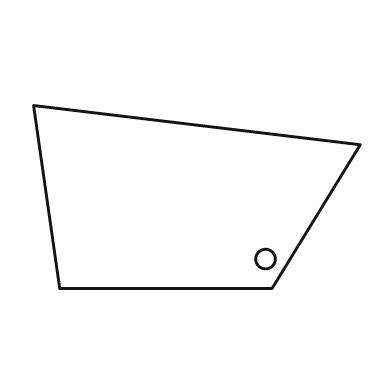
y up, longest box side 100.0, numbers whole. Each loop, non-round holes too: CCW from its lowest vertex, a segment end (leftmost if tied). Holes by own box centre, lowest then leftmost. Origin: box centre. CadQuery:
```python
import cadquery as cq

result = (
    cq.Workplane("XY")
    .moveTo(-42.0, -28.0)
    .lineTo(23.0, -28.0)
    .lineTo(50.0, 16.0)
    .lineTo(-50.0, 28.0)
    .close()
    .moveTo(21.0, -19.0)
    .circle(3.0)
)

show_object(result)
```